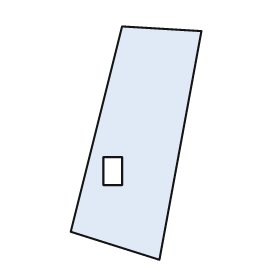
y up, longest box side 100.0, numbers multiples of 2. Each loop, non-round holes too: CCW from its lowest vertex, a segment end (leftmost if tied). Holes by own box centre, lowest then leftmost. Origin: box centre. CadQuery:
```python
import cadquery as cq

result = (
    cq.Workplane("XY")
    .moveTo(10.0, -50.0)
    .lineTo(28.0, 48.0)
    .lineTo(-6.0, 50.0)
    .lineTo(-28.0, -38.0)
    .close()
    .moveTo(-14.0, -18.0)
    .lineTo(-6.0, -18.0)
    .lineTo(-6.0, -6.0)
    .lineTo(-14.0, -6.0)
    .close()
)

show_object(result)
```